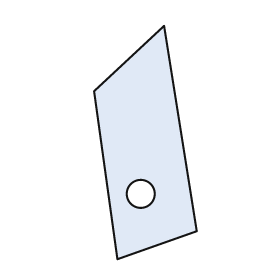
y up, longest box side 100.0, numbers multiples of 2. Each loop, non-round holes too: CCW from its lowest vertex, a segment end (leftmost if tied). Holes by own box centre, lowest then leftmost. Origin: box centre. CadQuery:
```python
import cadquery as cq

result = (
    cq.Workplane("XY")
    .moveTo(-12.0, -50.0)
    .lineTo(22.0, -38.0)
    .lineTo(8.0, 50.0)
    .lineTo(-22.0, 22.0)
    .close()
    .moveTo(-2.0, -22.0)
    .circle(6.0)
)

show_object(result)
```